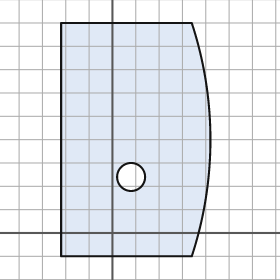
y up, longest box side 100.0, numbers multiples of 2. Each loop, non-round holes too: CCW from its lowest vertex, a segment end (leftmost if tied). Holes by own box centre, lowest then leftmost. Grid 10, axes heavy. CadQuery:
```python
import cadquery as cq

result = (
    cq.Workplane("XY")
    .moveTo(-22.0, -10.0)
    .lineTo(34.0, -10.0)
    .threePointArc((42.0, 40.0), (34.0, 90.0))
    .lineTo(-22.0, 90.0)
    .close()
    .moveTo(8.0, 24.0)
    .circle(6.0)
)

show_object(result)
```